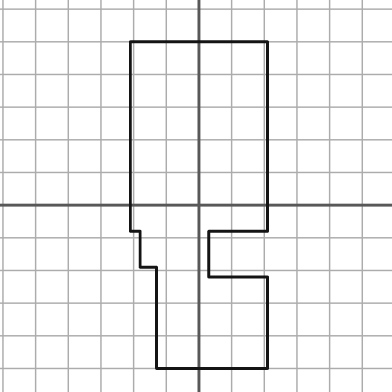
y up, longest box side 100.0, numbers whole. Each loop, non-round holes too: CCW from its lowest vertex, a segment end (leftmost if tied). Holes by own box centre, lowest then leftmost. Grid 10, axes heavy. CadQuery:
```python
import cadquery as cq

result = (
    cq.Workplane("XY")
    .moveTo(-13.0, -50.0)
    .lineTo(21.0, -50.0)
    .lineTo(21.0, -22.0)
    .lineTo(3.0, -22.0)
    .lineTo(3.0, -8.0)
    .lineTo(21.0, -8.0)
    .lineTo(21.0, 50.0)
    .lineTo(-21.0, 50.0)
    .lineTo(-21.0, -8.0)
    .lineTo(-18.0, -8.0)
    .lineTo(-18.0, -19.0)
    .lineTo(-13.0, -19.0)
    .close()
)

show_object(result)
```